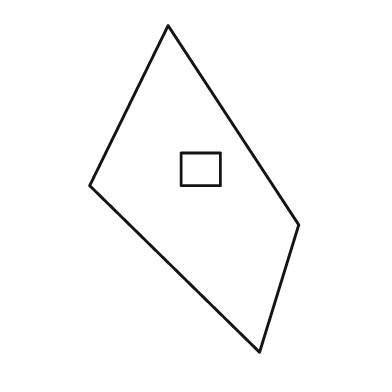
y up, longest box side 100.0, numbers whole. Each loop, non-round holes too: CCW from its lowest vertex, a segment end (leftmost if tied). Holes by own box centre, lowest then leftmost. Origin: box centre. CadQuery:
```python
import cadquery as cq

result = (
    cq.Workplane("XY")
    .moveTo(20.0, -50.0)
    .lineTo(32.0, -11.0)
    .lineTo(-8.0, 50.0)
    .lineTo(-32.0, 1.0)
    .close()
    .moveTo(-4.0, 1.0)
    .lineTo(8.0, 1.0)
    .lineTo(8.0, 11.0)
    .lineTo(-4.0, 11.0)
    .close()
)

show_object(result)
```